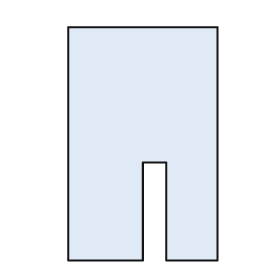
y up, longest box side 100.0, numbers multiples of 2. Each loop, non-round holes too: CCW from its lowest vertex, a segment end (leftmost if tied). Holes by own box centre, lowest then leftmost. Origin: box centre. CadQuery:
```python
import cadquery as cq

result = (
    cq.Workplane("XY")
    .moveTo(-32.0, -50.0)
    .lineTo(0.0, -50.0)
    .lineTo(0.0, -8.0)
    .lineTo(10.0, -8.0)
    .lineTo(10.0, -50.0)
    .lineTo(32.0, -50.0)
    .lineTo(32.0, 50.0)
    .lineTo(-32.0, 50.0)
    .close()
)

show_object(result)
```